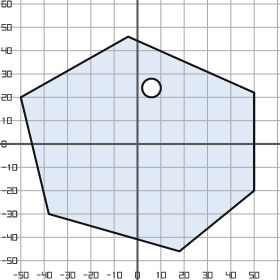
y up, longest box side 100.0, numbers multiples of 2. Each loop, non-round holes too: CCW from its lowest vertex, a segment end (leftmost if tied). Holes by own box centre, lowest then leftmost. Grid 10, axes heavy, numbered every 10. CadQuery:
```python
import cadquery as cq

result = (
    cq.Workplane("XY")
    .moveTo(18.0, -46.0)
    .lineTo(50.0, -20.0)
    .lineTo(50.0, 22.0)
    .lineTo(-4.0, 46.0)
    .lineTo(-50.0, 20.0)
    .lineTo(-38.0, -30.0)
    .close()
    .moveTo(6.0, 24.0)
    .circle(4.0)
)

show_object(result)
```